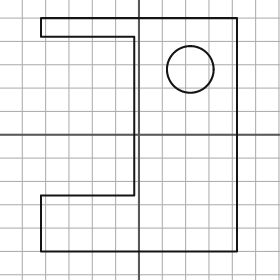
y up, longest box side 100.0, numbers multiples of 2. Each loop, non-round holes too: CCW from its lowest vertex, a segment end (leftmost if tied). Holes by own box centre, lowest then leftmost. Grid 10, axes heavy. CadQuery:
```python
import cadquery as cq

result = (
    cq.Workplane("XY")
    .moveTo(-42.0, -50.0)
    .lineTo(42.0, -50.0)
    .lineTo(42.0, 50.0)
    .lineTo(-42.0, 50.0)
    .lineTo(-42.0, 42.0)
    .lineTo(-2.0, 42.0)
    .lineTo(-2.0, -26.0)
    .lineTo(-42.0, -26.0)
    .close()
    .moveTo(22.0, 28.0)
    .circle(10.0)
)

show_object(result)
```